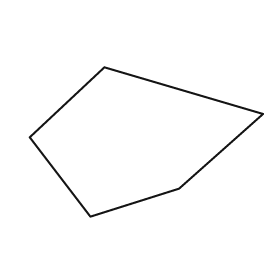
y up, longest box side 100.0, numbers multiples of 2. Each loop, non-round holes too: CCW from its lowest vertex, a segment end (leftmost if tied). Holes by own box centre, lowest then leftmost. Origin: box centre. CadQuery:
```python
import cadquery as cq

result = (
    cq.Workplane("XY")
    .moveTo(-24.0, -32.0)
    .lineTo(14.0, -20.0)
    .lineTo(50.0, 12.0)
    .lineTo(-18.0, 32.0)
    .lineTo(-50.0, 2.0)
    .close()
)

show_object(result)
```